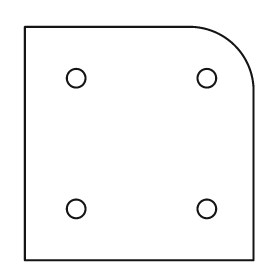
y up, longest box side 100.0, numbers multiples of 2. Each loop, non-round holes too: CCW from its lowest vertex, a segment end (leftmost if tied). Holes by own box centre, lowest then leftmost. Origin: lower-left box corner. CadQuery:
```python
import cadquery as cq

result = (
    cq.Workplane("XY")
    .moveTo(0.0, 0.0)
    .lineTo(98.0, 0.0)
    .lineTo(98.0, 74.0)
    .threePointArc((90.0, 92.0), (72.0, 100.0))
    .lineTo(0.0, 100.0)
    .close()
    .moveTo(22.0, 22.0)
    .circle(4.0)
    .moveTo(78.0, 22.0)
    .circle(4.0)
    .moveTo(22.0, 78.0)
    .circle(4.0)
    .moveTo(78.0, 78.0)
    .circle(4.0)
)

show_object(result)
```